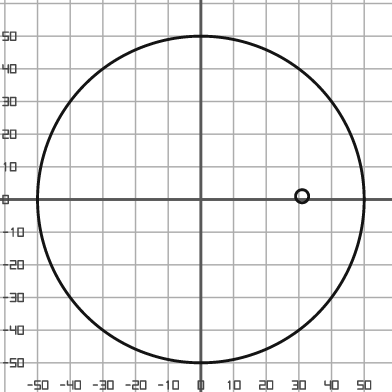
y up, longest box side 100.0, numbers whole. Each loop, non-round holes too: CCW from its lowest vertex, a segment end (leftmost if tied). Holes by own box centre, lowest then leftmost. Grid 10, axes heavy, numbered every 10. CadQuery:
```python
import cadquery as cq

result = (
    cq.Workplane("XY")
    .moveTo(0.0, 0.0)
    .circle(50.0)
    .moveTo(31.0, 1.0)
    .circle(2.0)
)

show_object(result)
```